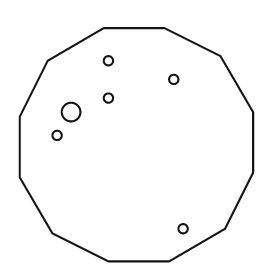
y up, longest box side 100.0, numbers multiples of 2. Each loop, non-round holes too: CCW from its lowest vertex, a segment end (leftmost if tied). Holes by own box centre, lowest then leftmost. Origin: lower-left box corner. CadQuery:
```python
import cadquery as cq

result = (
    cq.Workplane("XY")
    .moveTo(38.0, 0.0)
    .lineTo(64.0, 0.0)
    .lineTo(88.0, 14.0)
    .lineTo(100.0, 38.0)
    .lineTo(100.0, 64.0)
    .lineTo(86.0, 88.0)
    .lineTo(62.0, 100.0)
    .lineTo(36.0, 100.0)
    .lineTo(12.0, 86.0)
    .lineTo(0.0, 62.0)
    .lineTo(0.0, 36.0)
    .lineTo(14.0, 12.0)
    .close()
    .moveTo(70.0, 14.0)
    .circle(2.0)
    .moveTo(16.0, 54.0)
    .circle(2.0)
    .moveTo(22.0, 64.0)
    .circle(4.0)
    .moveTo(38.0, 70.0)
    .circle(2.0)
    .moveTo(66.0, 78.0)
    .circle(2.0)
    .moveTo(38.0, 86.0)
    .circle(2.0)
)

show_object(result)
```